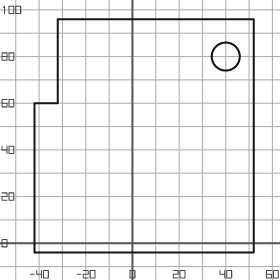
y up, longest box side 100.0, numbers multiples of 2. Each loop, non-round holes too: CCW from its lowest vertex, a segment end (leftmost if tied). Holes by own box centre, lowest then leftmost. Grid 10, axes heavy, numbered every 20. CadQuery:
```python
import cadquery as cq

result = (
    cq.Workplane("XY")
    .moveTo(-42.0, -4.0)
    .lineTo(52.0, -4.0)
    .lineTo(52.0, 96.0)
    .lineTo(-32.0, 96.0)
    .lineTo(-32.0, 60.0)
    .lineTo(-42.0, 60.0)
    .close()
    .moveTo(40.0, 80.0)
    .circle(6.0)
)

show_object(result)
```